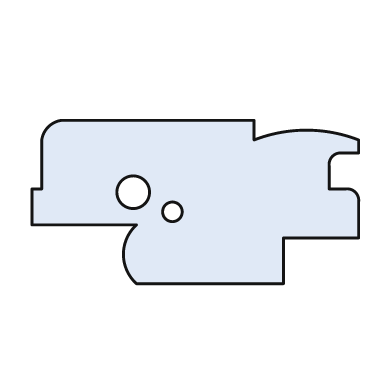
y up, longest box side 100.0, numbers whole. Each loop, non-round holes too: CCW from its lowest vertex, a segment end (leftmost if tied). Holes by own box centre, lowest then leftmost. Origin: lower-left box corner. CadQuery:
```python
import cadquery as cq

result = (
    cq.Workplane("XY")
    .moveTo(32.0, 0.0)
    .lineTo(77.0, 0.0)
    .lineTo(77.0, 14.0)
    .lineTo(100.0, 14.0)
    .lineTo(100.0, 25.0)
    .threePointArc((99.0, 28.0), (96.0, 29.0))
    .lineTo(91.0, 29.0)
    .lineTo(91.0, 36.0)
    .threePointArc((92.0, 39.0), (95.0, 40.0))
    .lineTo(100.0, 40.0)
    .lineTo(100.0, 44.0)
    .threePointArc((84.0, 47.0), (68.0, 44.0))
    .lineTo(68.0, 50.0)
    .lineTo(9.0, 50.0)
    .threePointArc((5.0, 48.0), (3.0, 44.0))
    .lineTo(3.0, 29.0)
    .lineTo(0.0, 29.0)
    .lineTo(0.0, 18.0)
    .lineTo(32.0, 18.0)
    .threePointArc((28.0, 9.0), (32.0, 0.0))
    .close()
    .moveTo(43.0, 22.0)
    .circle(3.0)
    .moveTo(31.0, 28.0)
    .circle(5.0)
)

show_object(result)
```